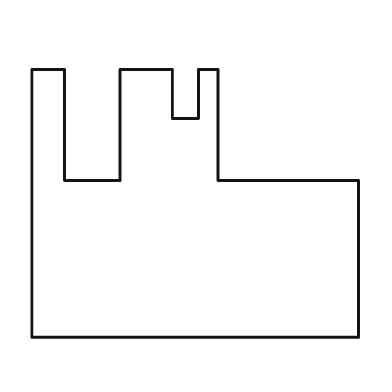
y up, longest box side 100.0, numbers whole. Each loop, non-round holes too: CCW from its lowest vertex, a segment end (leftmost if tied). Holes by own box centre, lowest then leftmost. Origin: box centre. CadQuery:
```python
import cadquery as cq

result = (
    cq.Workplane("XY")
    .moveTo(-50.0, -41.0)
    .lineTo(50.0, -41.0)
    .lineTo(50.0, 7.0)
    .lineTo(7.0, 7.0)
    .lineTo(7.0, 41.0)
    .lineTo(1.0, 41.0)
    .lineTo(1.0, 26.0)
    .lineTo(-7.0, 26.0)
    .lineTo(-7.0, 41.0)
    .lineTo(-23.0, 41.0)
    .lineTo(-23.0, 7.0)
    .lineTo(-40.0, 7.0)
    .lineTo(-40.0, 41.0)
    .lineTo(-50.0, 41.0)
    .close()
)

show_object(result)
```